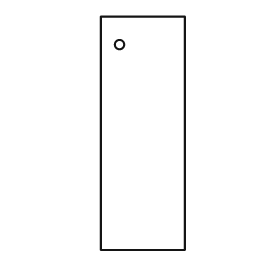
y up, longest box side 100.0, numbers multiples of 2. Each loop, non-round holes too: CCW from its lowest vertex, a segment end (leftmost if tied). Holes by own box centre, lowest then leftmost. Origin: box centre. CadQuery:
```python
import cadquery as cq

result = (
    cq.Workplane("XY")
    .moveTo(-18.0, -50.0)
    .lineTo(18.0, -50.0)
    .lineTo(18.0, 50.0)
    .lineTo(-18.0, 50.0)
    .close()
    .moveTo(-10.0, 38.0)
    .circle(2.0)
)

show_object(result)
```